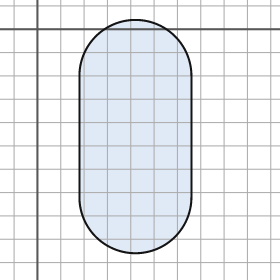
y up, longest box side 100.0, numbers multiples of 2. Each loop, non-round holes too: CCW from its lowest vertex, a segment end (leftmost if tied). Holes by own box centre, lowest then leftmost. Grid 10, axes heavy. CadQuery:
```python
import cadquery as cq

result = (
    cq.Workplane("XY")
    .moveTo(18.0, -72.0)
    .threePointArc((42.0, -96.0), (66.0, -72.0))
    .lineTo(66.0, -20.0)
    .threePointArc((42.0, 4.0), (18.0, -20.0))
    .close()
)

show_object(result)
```